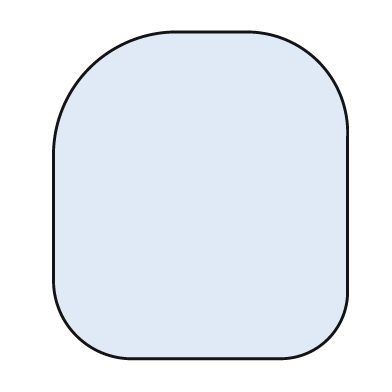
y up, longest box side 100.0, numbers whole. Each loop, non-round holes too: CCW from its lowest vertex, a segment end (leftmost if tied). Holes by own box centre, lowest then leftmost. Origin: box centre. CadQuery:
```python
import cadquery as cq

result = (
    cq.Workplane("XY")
    .moveTo(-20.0, -50.0)
    .lineTo(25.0, -50.0)
    .threePointArc((39.0, -44.0), (45.0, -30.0))
    .lineTo(45.0, 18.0)
    .threePointArc((36.0, 41.0), (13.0, 50.0))
    .lineTo(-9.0, 50.0)
    .threePointArc((-34.0, 39.0), (-45.0, 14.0))
    .lineTo(-45.0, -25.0)
    .threePointArc((-38.0, -43.0), (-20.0, -50.0))
    .close()
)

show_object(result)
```